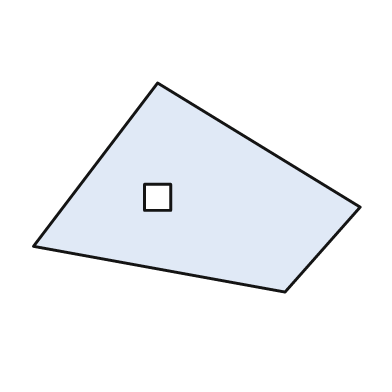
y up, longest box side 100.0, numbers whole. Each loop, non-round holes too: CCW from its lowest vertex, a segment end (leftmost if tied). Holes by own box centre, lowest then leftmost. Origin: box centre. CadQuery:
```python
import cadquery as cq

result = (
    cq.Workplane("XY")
    .moveTo(27.0, -32.0)
    .lineTo(50.0, -6.0)
    .lineTo(-12.0, 32.0)
    .lineTo(-50.0, -18.0)
    .close()
    .moveTo(-16.0, -7.0)
    .lineTo(-8.0, -7.0)
    .lineTo(-8.0, 1.0)
    .lineTo(-16.0, 1.0)
    .close()
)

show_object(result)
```